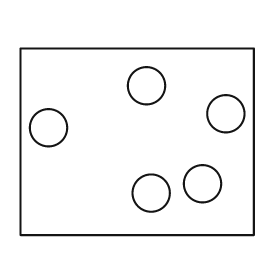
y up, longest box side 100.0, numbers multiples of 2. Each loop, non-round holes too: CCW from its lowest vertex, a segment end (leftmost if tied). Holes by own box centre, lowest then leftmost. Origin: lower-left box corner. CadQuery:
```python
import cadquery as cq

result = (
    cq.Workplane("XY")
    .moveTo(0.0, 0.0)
    .lineTo(100.0, 0.0)
    .lineTo(100.0, 80.0)
    .lineTo(0.0, 80.0)
    .close()
    .moveTo(56.0, 18.0)
    .circle(8.0)
    .moveTo(78.0, 22.0)
    .circle(8.0)
    .moveTo(12.0, 46.0)
    .circle(8.0)
    .moveTo(88.0, 52.0)
    .circle(8.0)
    .moveTo(54.0, 64.0)
    .circle(8.0)
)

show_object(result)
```